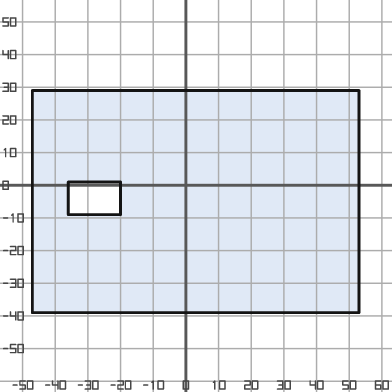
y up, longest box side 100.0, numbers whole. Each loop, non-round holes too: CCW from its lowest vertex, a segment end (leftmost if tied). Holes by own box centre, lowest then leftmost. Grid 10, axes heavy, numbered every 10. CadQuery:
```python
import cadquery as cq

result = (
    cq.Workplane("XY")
    .moveTo(-47.0, -39.0)
    .lineTo(53.0, -39.0)
    .lineTo(53.0, 29.0)
    .lineTo(-47.0, 29.0)
    .close()
    .moveTo(-36.0, -9.0)
    .lineTo(-20.0, -9.0)
    .lineTo(-20.0, 1.0)
    .lineTo(-36.0, 1.0)
    .close()
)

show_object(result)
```